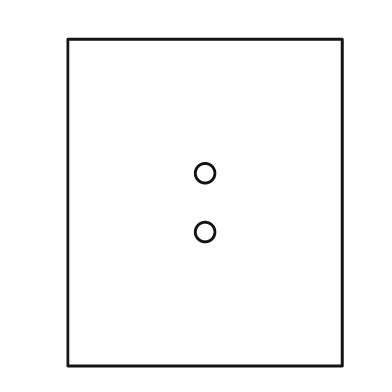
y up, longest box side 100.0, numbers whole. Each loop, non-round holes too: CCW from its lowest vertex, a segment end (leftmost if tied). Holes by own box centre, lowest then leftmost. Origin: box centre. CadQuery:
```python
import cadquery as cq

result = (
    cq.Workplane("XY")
    .moveTo(-42.0, -50.0)
    .lineTo(42.0, -50.0)
    .lineTo(42.0, 50.0)
    .lineTo(-42.0, 50.0)
    .close()
    .moveTo(0.0, -9.0)
    .circle(3.0)
    .moveTo(0.0, 9.0)
    .circle(3.0)
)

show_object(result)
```